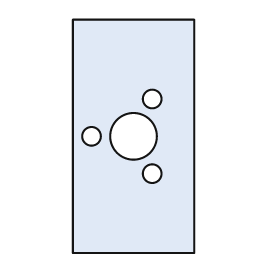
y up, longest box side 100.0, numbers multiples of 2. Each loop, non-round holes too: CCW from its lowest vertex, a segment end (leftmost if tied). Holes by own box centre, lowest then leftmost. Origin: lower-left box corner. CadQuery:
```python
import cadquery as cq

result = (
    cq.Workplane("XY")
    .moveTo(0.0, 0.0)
    .lineTo(52.0, 0.0)
    .lineTo(52.0, 100.0)
    .lineTo(0.0, 100.0)
    .close()
    .moveTo(34.0, 34.0)
    .circle(4.0)
    .moveTo(8.0, 50.0)
    .circle(4.0)
    .moveTo(26.0, 50.0)
    .circle(10.0)
    .moveTo(34.0, 66.0)
    .circle(4.0)
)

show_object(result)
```